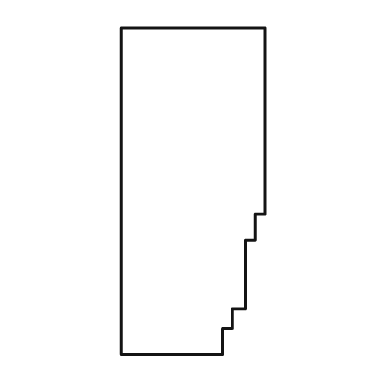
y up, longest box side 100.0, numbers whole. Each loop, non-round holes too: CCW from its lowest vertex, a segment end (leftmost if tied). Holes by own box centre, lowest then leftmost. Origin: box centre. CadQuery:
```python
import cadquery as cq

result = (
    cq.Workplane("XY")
    .moveTo(-22.0, -50.0)
    .lineTo(9.0, -50.0)
    .lineTo(9.0, -42.0)
    .lineTo(12.0, -42.0)
    .lineTo(12.0, -36.0)
    .lineTo(16.0, -36.0)
    .lineTo(16.0, -15.0)
    .lineTo(19.0, -15.0)
    .lineTo(19.0, -7.0)
    .lineTo(22.0, -7.0)
    .lineTo(22.0, 50.0)
    .lineTo(-22.0, 50.0)
    .close()
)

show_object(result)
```